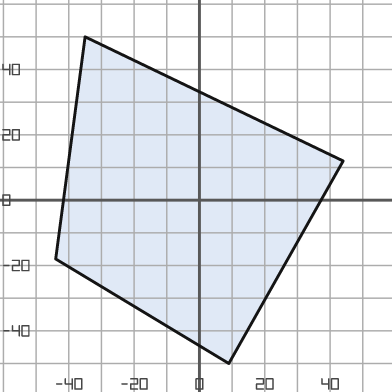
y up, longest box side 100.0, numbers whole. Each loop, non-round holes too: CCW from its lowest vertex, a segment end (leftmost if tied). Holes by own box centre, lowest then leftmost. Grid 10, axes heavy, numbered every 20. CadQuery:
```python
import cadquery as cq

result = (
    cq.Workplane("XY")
    .moveTo(9.0, -50.0)
    .lineTo(44.0, 12.0)
    .lineTo(-35.0, 50.0)
    .lineTo(-44.0, -18.0)
    .close()
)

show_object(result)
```